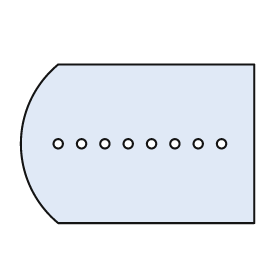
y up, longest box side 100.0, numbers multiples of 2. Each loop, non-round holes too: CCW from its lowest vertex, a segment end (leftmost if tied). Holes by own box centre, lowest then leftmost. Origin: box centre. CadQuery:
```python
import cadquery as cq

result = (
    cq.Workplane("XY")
    .moveTo(-34.0, -34.0)
    .lineTo(50.0, -34.0)
    .lineTo(50.0, 34.0)
    .lineTo(-34.0, 34.0)
    .threePointArc((-50.0, 0.0), (-34.0, -34.0))
    .close()
    .moveTo(-34.0, 0.0)
    .circle(2.0)
    .moveTo(-24.0, 0.0)
    .circle(2.0)
    .moveTo(-14.0, 0.0)
    .circle(2.0)
    .moveTo(-4.0, 0.0)
    .circle(2.0)
    .moveTo(6.0, 0.0)
    .circle(2.0)
    .moveTo(16.0, 0.0)
    .circle(2.0)
    .moveTo(26.0, 0.0)
    .circle(2.0)
    .moveTo(36.0, 0.0)
    .circle(2.0)
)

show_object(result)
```